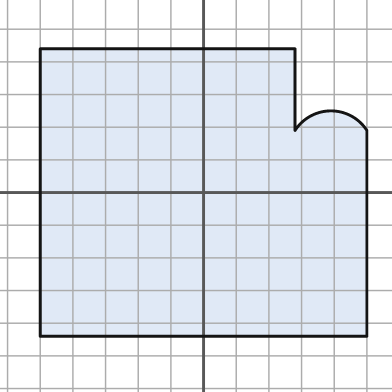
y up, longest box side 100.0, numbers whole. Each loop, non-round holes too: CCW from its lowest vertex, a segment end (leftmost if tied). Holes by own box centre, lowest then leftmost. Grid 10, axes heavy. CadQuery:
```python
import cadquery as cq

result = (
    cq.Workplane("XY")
    .moveTo(-50.0, -44.0)
    .lineTo(50.0, -44.0)
    .lineTo(50.0, 19.0)
    .threePointArc((39.0, 25.0), (28.0, 19.0))
    .lineTo(28.0, 44.0)
    .lineTo(-50.0, 44.0)
    .close()
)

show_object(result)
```